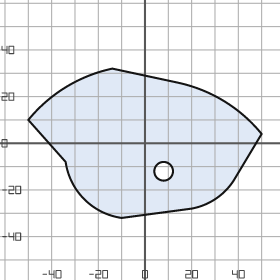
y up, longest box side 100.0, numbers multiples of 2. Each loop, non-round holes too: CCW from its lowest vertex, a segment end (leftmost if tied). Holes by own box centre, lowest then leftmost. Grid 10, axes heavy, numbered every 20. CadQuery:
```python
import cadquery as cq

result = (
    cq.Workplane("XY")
    .moveTo(-10.0, -32.0)
    .lineTo(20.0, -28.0)
    .threePointArc((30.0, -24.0), (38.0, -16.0))
    .lineTo(50.0, 4.0)
    .threePointArc((34.0, 18.0), (14.0, 26.0))
    .lineTo(-14.0, 32.0)
    .threePointArc((-34.0, 24.0), (-50.0, 10.0))
    .lineTo(-34.0, -8.0)
    .threePointArc((-26.0, -24.0), (-10.0, -32.0))
    .close()
    .moveTo(8.0, -12.0)
    .circle(4.0)
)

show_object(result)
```